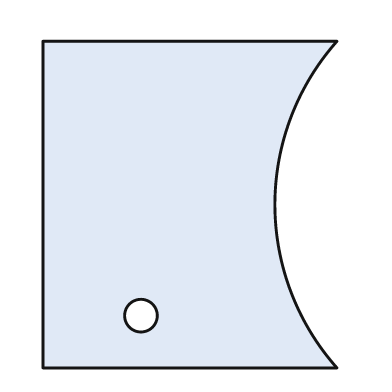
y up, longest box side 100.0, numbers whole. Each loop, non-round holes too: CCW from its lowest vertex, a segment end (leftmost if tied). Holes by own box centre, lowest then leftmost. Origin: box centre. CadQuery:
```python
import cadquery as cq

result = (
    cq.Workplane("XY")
    .moveTo(-45.0, -50.0)
    .lineTo(45.0, -50.0)
    .threePointArc((26.0, 0.0), (45.0, 50.0))
    .lineTo(-45.0, 50.0)
    .close()
    .moveTo(-15.0, -34.0)
    .circle(5.0)
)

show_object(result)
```